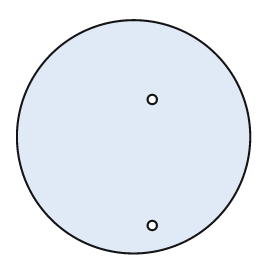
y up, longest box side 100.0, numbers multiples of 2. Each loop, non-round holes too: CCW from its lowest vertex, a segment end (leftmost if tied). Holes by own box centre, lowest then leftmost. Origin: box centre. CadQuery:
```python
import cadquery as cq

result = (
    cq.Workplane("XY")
    .moveTo(0.0, 0.0)
    .circle(50.0)
    .moveTo(8.0, -38.0)
    .circle(2.0)
    .moveTo(8.0, 16.0)
    .circle(2.0)
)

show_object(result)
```